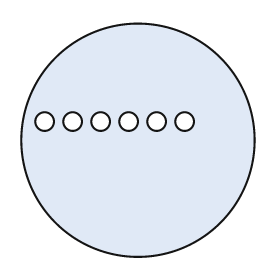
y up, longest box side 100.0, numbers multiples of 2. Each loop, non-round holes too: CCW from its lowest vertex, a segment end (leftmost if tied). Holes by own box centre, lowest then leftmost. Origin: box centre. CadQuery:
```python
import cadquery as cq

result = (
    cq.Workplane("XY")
    .moveTo(0.0, 0.0)
    .circle(50.0)
    .moveTo(-40.0, 8.0)
    .circle(4.0)
    .moveTo(-28.0, 8.0)
    .circle(4.0)
    .moveTo(-16.0, 8.0)
    .circle(4.0)
    .moveTo(-4.0, 8.0)
    .circle(4.0)
    .moveTo(8.0, 8.0)
    .circle(4.0)
    .moveTo(20.0, 8.0)
    .circle(4.0)
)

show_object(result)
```